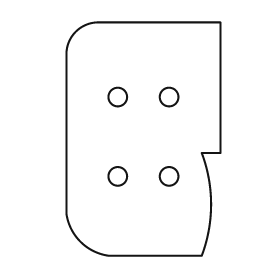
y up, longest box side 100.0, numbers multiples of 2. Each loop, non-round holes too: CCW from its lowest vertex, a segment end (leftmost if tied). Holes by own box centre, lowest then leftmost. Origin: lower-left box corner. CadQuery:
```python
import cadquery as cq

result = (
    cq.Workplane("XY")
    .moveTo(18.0, 0.0)
    .lineTo(58.0, 0.0)
    .threePointArc((62.0, 22.0), (58.0, 44.0))
    .lineTo(66.0, 44.0)
    .lineTo(66.0, 100.0)
    .lineTo(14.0, 100.0)
    .threePointArc((4.0, 96.0), (0.0, 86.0))
    .lineTo(0.0, 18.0)
    .threePointArc((6.0, 6.0), (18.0, 0.0))
    .close()
    .moveTo(22.0, 34.0)
    .circle(4.0)
    .moveTo(44.0, 34.0)
    .circle(4.0)
    .moveTo(22.0, 68.0)
    .circle(4.0)
    .moveTo(44.0, 68.0)
    .circle(4.0)
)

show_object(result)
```